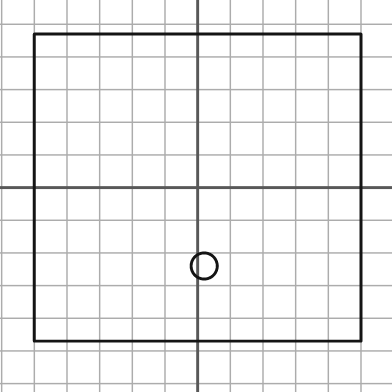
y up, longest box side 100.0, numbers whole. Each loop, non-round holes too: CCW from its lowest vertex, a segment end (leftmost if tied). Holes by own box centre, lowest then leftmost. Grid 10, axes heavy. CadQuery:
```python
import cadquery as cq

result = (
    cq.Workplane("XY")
    .moveTo(-50.0, -47.0)
    .lineTo(50.0, -47.0)
    .lineTo(50.0, 47.0)
    .lineTo(-50.0, 47.0)
    .close()
    .moveTo(2.0, -24.0)
    .circle(4.0)
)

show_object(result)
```